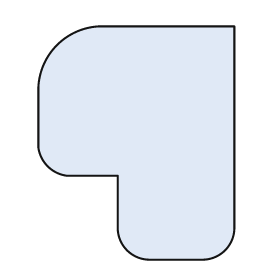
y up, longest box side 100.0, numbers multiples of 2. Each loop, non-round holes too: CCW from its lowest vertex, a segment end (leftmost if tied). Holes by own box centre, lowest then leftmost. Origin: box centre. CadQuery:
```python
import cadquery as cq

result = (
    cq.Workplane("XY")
    .moveTo(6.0, -50.0)
    .lineTo(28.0, -50.0)
    .threePointArc((38.0, -46.0), (42.0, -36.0))
    .lineTo(42.0, 50.0)
    .lineTo(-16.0, 50.0)
    .threePointArc((-34.0, 42.0), (-42.0, 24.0))
    .lineTo(-42.0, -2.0)
    .threePointArc((-38.0, -10.0), (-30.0, -14.0))
    .lineTo(-8.0, -14.0)
    .lineTo(-8.0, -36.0)
    .threePointArc((-4.0, -46.0), (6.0, -50.0))
    .close()
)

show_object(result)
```